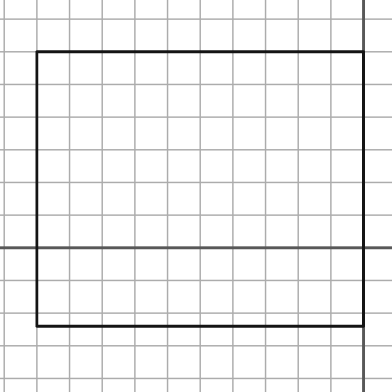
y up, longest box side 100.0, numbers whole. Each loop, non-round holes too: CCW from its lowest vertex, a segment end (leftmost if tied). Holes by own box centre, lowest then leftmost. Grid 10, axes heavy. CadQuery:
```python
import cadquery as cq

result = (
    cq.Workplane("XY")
    .moveTo(-100.0, -24.0)
    .lineTo(0.0, -24.0)
    .lineTo(0.0, 60.0)
    .lineTo(-100.0, 60.0)
    .close()
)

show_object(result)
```